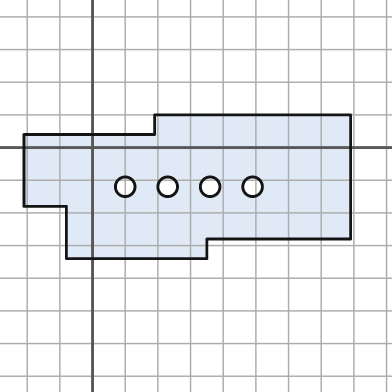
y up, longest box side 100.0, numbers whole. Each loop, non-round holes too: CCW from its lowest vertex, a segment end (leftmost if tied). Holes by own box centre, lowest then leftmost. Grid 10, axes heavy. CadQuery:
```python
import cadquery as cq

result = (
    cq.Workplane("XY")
    .moveTo(-8.0, -34.0)
    .lineTo(35.0, -34.0)
    .lineTo(35.0, -28.0)
    .lineTo(79.0, -28.0)
    .lineTo(79.0, 10.0)
    .lineTo(19.0, 10.0)
    .lineTo(19.0, 4.0)
    .lineTo(-21.0, 4.0)
    .lineTo(-21.0, -18.0)
    .lineTo(-8.0, -18.0)
    .close()
    .moveTo(10.0, -12.0)
    .circle(3.0)
    .moveTo(23.0, -12.0)
    .circle(3.0)
    .moveTo(36.0, -12.0)
    .circle(3.0)
    .moveTo(49.0, -12.0)
    .circle(3.0)
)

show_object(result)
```